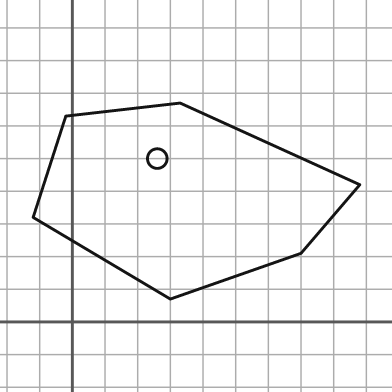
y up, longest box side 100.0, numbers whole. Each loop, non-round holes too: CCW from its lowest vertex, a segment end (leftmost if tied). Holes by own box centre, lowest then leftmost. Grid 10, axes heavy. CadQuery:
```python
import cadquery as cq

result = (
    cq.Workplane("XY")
    .moveTo(30.0, 7.0)
    .lineTo(70.0, 21.0)
    .lineTo(88.0, 42.0)
    .lineTo(33.0, 67.0)
    .lineTo(-2.0, 63.0)
    .lineTo(-12.0, 32.0)
    .close()
    .moveTo(26.0, 50.0)
    .circle(3.0)
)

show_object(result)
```